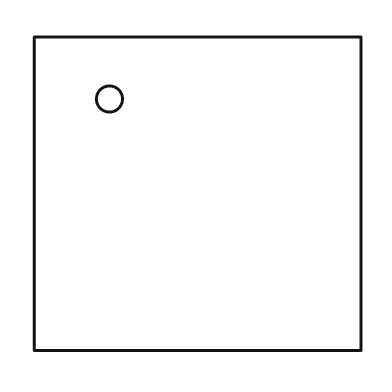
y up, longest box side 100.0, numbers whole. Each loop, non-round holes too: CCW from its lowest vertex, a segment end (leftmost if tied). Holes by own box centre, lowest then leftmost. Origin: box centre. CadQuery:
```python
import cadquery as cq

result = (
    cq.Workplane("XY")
    .moveTo(-50.0, -48.0)
    .lineTo(50.0, -48.0)
    .lineTo(50.0, 48.0)
    .lineTo(-50.0, 48.0)
    .close()
    .moveTo(-27.0, 29.0)
    .circle(4.0)
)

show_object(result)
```